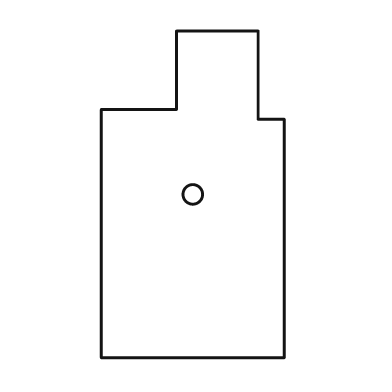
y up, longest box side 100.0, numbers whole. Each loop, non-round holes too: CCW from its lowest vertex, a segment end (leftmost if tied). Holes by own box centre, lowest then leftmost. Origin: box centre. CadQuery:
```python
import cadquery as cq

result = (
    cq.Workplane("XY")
    .moveTo(-28.0, -50.0)
    .lineTo(28.0, -50.0)
    .lineTo(28.0, 23.0)
    .lineTo(20.0, 23.0)
    .lineTo(20.0, 50.0)
    .lineTo(-5.0, 50.0)
    .lineTo(-5.0, 26.0)
    .lineTo(-28.0, 26.0)
    .close()
    .moveTo(0.0, 0.0)
    .circle(3.0)
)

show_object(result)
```